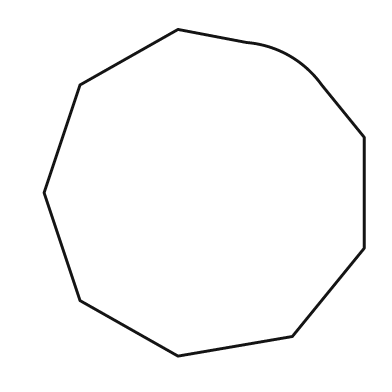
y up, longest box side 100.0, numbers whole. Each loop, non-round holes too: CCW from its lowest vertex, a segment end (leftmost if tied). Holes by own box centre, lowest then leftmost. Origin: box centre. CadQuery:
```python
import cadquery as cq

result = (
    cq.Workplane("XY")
    .moveTo(-8.0, -50.0)
    .lineTo(27.0, -44.0)
    .lineTo(49.0, -17.0)
    .lineTo(49.0, 17.0)
    .lineTo(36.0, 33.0)
    .threePointArc((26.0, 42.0), (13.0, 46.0))
    .lineTo(-8.0, 50.0)
    .lineTo(-38.0, 33.0)
    .lineTo(-49.0, 0.0)
    .lineTo(-38.0, -33.0)
    .close()
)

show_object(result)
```